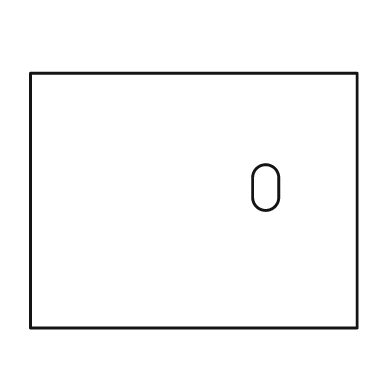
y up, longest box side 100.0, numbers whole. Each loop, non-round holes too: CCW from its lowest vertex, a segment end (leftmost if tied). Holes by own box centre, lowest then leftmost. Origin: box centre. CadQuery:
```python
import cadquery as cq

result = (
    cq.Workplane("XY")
    .moveTo(-50.0, -39.0)
    .lineTo(50.0, -39.0)
    .lineTo(50.0, 39.0)
    .lineTo(-50.0, 39.0)
    .close()
    .moveTo(18.0, 1.0)
    .threePointArc((22.0, -3.0), (26.0, 1.0))
    .lineTo(26.0, 7.0)
    .threePointArc((22.0, 11.0), (18.0, 7.0))
    .close()
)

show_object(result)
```